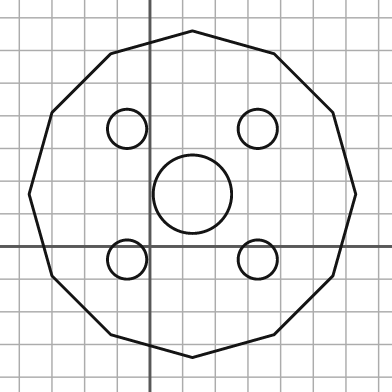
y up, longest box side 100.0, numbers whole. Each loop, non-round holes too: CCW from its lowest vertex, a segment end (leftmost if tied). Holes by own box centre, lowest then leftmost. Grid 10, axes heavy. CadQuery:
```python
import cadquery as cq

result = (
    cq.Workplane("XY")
    .moveTo(13.0, -34.0)
    .lineTo(38.0, -27.0)
    .lineTo(56.0, -9.0)
    .lineTo(63.0, 16.0)
    .lineTo(56.0, 41.0)
    .lineTo(38.0, 59.0)
    .lineTo(13.0, 66.0)
    .lineTo(-12.0, 59.0)
    .lineTo(-30.0, 41.0)
    .lineTo(-37.0, 16.0)
    .lineTo(-30.0, -9.0)
    .lineTo(-12.0, -27.0)
    .close()
    .moveTo(-7.0, -4.0)
    .circle(6.0)
    .moveTo(33.0, -4.0)
    .circle(6.0)
    .moveTo(13.0, 16.0)
    .circle(12.0)
    .moveTo(-7.0, 36.0)
    .circle(6.0)
    .moveTo(33.0, 36.0)
    .circle(6.0)
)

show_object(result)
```